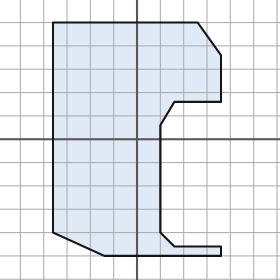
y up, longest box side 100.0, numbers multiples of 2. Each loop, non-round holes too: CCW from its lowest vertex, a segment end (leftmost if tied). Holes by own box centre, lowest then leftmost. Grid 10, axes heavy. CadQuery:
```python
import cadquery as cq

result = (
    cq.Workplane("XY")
    .moveTo(-14.0, -50.0)
    .lineTo(36.0, -50.0)
    .lineTo(36.0, -46.0)
    .lineTo(16.0, -46.0)
    .lineTo(10.0, -40.0)
    .lineTo(10.0, 6.0)
    .lineTo(16.0, 16.0)
    .lineTo(36.0, 16.0)
    .lineTo(36.0, 36.0)
    .lineTo(26.0, 50.0)
    .lineTo(-36.0, 50.0)
    .lineTo(-36.0, -40.0)
    .close()
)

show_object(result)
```